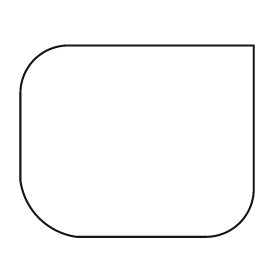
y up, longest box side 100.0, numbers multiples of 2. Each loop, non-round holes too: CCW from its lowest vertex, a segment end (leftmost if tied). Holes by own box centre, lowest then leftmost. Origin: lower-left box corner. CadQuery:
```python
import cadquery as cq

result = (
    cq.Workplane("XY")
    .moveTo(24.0, 0.0)
    .lineTo(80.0, 0.0)
    .threePointArc((94.0, 6.0), (100.0, 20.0))
    .lineTo(100.0, 82.0)
    .lineTo(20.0, 82.0)
    .threePointArc((6.0, 76.0), (0.0, 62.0))
    .lineTo(0.0, 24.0)
    .threePointArc((8.0, 8.0), (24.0, 0.0))
    .close()
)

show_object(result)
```